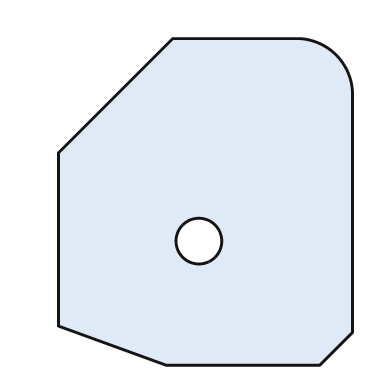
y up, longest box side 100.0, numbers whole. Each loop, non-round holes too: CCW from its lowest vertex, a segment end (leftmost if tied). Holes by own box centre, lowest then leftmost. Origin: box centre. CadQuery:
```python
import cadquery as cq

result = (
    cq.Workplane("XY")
    .moveTo(-12.0, -50.0)
    .lineTo(35.0, -50.0)
    .lineTo(45.0, -40.0)
    .lineTo(45.0, 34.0)
    .threePointArc((40.0, 45.0), (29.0, 50.0))
    .lineTo(-10.0, 50.0)
    .lineTo(-45.0, 15.0)
    .lineTo(-45.0, -38.0)
    .close()
    .moveTo(-2.0, -12.0)
    .circle(7.0)
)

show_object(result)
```